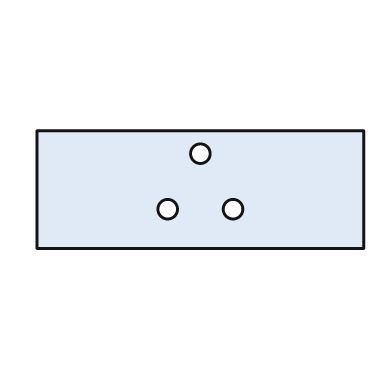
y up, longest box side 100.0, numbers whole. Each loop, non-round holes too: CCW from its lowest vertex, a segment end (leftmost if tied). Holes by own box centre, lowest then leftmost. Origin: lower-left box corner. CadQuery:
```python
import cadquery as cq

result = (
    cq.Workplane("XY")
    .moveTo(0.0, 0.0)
    .lineTo(100.0, 0.0)
    .lineTo(100.0, 36.0)
    .lineTo(0.0, 36.0)
    .close()
    .moveTo(40.0, 12.0)
    .circle(3.0)
    .moveTo(60.0, 12.0)
    .circle(3.0)
    .moveTo(50.0, 29.0)
    .circle(3.0)
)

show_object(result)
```